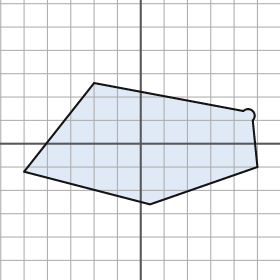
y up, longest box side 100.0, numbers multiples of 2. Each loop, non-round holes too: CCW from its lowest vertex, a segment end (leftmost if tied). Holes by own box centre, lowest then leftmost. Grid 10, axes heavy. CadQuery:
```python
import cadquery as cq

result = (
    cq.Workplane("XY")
    .moveTo(4.0, -26.0)
    .lineTo(50.0, -10.0)
    .lineTo(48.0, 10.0)
    .threePointArc((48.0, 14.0), (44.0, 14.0))
    .lineTo(-20.0, 26.0)
    .lineTo(-50.0, -12.0)
    .close()
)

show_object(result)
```